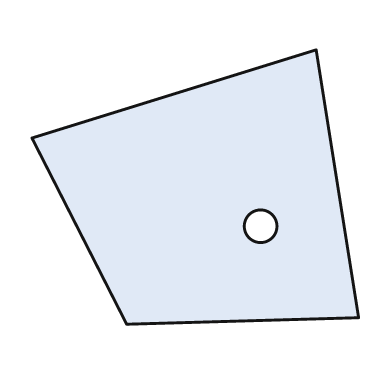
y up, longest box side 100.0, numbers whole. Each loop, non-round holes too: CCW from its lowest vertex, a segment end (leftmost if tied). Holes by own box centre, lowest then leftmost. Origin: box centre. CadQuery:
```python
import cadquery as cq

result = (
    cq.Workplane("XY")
    .moveTo(-21.0, -42.0)
    .lineTo(50.0, -40.0)
    .lineTo(37.0, 42.0)
    .lineTo(-50.0, 15.0)
    .close()
    .moveTo(20.0, -12.0)
    .circle(5.0)
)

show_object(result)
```